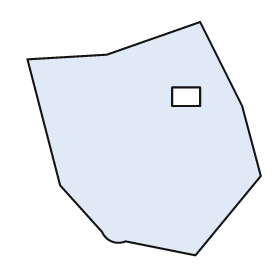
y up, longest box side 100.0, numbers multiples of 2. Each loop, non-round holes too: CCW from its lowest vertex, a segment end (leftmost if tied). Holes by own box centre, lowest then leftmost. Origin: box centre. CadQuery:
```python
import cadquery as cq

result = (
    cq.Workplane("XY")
    .moveTo(22.0, -50.0)
    .lineTo(50.0, -16.0)
    .lineTo(42.0, 14.0)
    .lineTo(24.0, 50.0)
    .lineTo(-16.0, 36.0)
    .lineTo(-50.0, 34.0)
    .lineTo(-36.0, -20.0)
    .lineTo(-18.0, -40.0)
    .threePointArc((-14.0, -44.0), (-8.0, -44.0))
    .close()
    .moveTo(12.0, 14.0)
    .lineTo(24.0, 14.0)
    .lineTo(24.0, 22.0)
    .lineTo(12.0, 22.0)
    .close()
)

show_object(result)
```